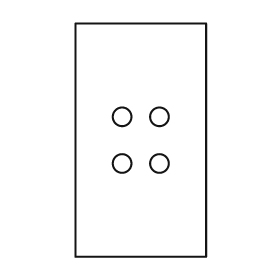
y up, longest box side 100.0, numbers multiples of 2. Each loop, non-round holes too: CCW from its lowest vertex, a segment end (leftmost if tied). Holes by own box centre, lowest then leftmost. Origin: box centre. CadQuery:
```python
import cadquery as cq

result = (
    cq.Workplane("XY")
    .moveTo(-28.0, -50.0)
    .lineTo(28.0, -50.0)
    .lineTo(28.0, 50.0)
    .lineTo(-28.0, 50.0)
    .close()
    .moveTo(-8.0, -10.0)
    .circle(4.0)
    .moveTo(8.0, -10.0)
    .circle(4.0)
    .moveTo(-8.0, 10.0)
    .circle(4.0)
    .moveTo(8.0, 10.0)
    .circle(4.0)
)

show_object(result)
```